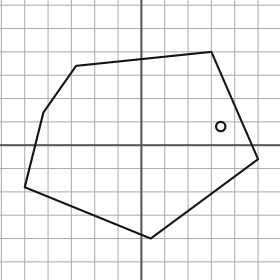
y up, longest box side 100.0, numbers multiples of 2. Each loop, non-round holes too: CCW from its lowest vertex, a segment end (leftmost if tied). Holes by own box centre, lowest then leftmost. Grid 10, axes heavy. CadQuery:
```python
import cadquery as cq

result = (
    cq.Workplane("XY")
    .moveTo(4.0, -40.0)
    .lineTo(50.0, -6.0)
    .lineTo(30.0, 40.0)
    .lineTo(-28.0, 34.0)
    .lineTo(-42.0, 14.0)
    .lineTo(-50.0, -18.0)
    .close()
    .moveTo(34.0, 8.0)
    .circle(2.0)
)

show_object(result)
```